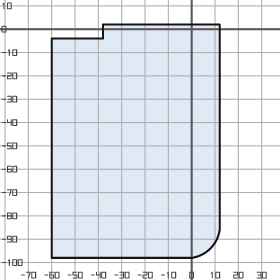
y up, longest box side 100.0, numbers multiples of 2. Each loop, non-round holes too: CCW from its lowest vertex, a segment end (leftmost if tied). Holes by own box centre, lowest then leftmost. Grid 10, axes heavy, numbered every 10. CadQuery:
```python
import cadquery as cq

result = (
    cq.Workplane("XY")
    .moveTo(-60.0, -98.0)
    .lineTo(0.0, -98.0)
    .threePointArc((8.0, -94.0), (12.0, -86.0))
    .lineTo(12.0, 2.0)
    .lineTo(-38.0, 2.0)
    .lineTo(-38.0, -4.0)
    .lineTo(-60.0, -4.0)
    .close()
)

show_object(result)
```